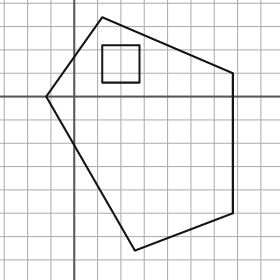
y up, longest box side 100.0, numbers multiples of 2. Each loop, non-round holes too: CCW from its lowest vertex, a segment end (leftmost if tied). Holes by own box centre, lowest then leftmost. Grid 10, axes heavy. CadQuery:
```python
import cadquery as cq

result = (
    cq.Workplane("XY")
    .moveTo(26.0, -66.0)
    .lineTo(68.0, -50.0)
    .lineTo(68.0, 10.0)
    .lineTo(12.0, 34.0)
    .lineTo(-12.0, 0.0)
    .close()
    .moveTo(12.0, 6.0)
    .lineTo(28.0, 6.0)
    .lineTo(28.0, 22.0)
    .lineTo(12.0, 22.0)
    .close()
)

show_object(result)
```